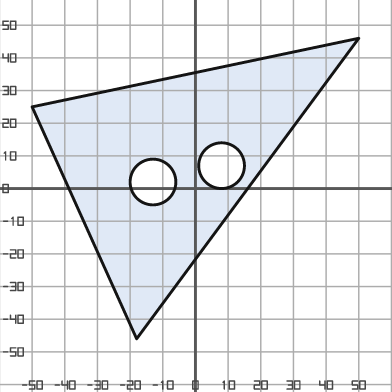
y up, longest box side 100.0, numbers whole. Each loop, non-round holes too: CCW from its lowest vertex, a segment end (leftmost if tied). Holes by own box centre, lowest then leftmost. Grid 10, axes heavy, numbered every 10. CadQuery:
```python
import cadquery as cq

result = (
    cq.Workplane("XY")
    .moveTo(-18.0, -46.0)
    .lineTo(50.0, 46.0)
    .lineTo(-50.0, 25.0)
    .close()
    .moveTo(-13.0, 2.0)
    .circle(7.0)
    .moveTo(8.0, 7.0)
    .circle(7.0)
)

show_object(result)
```